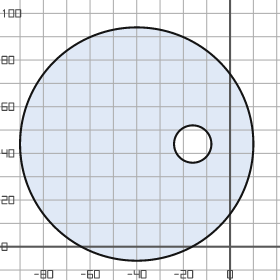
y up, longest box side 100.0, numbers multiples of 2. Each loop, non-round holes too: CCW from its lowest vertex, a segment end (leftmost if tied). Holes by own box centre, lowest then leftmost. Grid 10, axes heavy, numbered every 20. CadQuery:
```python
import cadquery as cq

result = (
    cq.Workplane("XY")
    .moveTo(-40.0, 44.0)
    .circle(50.0)
    .moveTo(-16.0, 44.0)
    .circle(8.0)
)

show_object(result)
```